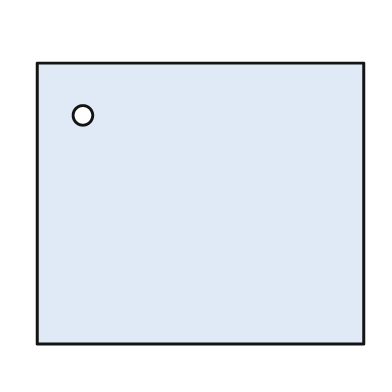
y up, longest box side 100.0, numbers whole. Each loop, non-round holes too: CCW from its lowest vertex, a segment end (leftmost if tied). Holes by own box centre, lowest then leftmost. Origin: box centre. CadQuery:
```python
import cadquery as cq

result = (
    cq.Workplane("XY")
    .moveTo(-50.0, -43.0)
    .lineTo(50.0, -43.0)
    .lineTo(50.0, 43.0)
    .lineTo(-50.0, 43.0)
    .close()
    .moveTo(-36.0, 27.0)
    .circle(3.0)
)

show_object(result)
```